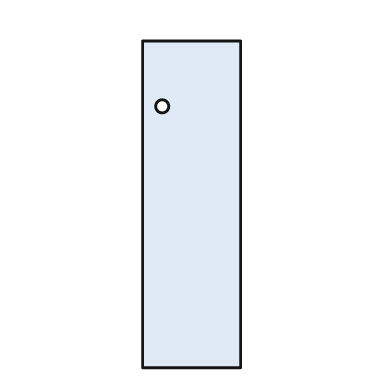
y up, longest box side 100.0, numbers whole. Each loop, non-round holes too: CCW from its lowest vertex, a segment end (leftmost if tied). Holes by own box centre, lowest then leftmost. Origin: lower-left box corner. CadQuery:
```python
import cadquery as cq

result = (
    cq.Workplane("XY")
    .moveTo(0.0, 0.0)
    .lineTo(30.0, 0.0)
    .lineTo(30.0, 100.0)
    .lineTo(0.0, 100.0)
    .close()
    .moveTo(6.0, 80.0)
    .circle(2.0)
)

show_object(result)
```